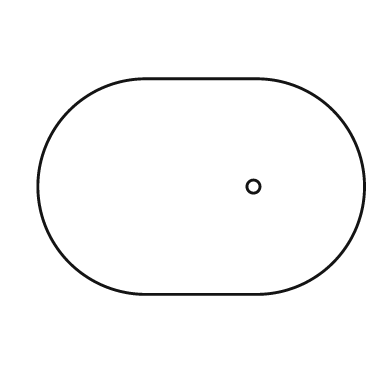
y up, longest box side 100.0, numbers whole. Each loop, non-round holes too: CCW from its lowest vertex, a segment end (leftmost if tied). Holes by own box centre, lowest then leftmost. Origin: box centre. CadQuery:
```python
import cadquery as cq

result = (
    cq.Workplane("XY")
    .moveTo(-17.0, -33.0)
    .lineTo(17.0, -33.0)
    .threePointArc((50.0, 0.0), (17.0, 33.0))
    .lineTo(-17.0, 33.0)
    .threePointArc((-50.0, 0.0), (-17.0, -33.0))
    .close()
    .moveTo(16.0, 0.0)
    .circle(2.0)
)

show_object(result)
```